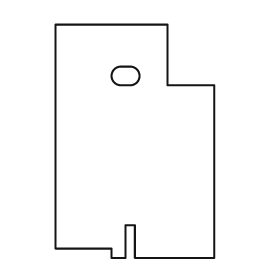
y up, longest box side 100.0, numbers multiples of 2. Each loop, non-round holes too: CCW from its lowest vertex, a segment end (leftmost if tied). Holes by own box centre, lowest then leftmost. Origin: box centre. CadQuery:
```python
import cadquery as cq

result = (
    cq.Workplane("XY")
    .moveTo(-10.0, -50.0)
    .lineTo(-4.0, -50.0)
    .lineTo(-4.0, -36.0)
    .lineTo(0.0, -36.0)
    .lineTo(0.0, -50.0)
    .lineTo(34.0, -50.0)
    .lineTo(34.0, 24.0)
    .lineTo(14.0, 24.0)
    .lineTo(14.0, 50.0)
    .lineTo(-34.0, 50.0)
    .lineTo(-34.0, -46.0)
    .lineTo(-10.0, -46.0)
    .close()
    .moveTo(-6.0, 24.0)
    .lineTo(-2.0, 24.0)
    .threePointArc((2.0, 28.0), (-2.0, 32.0))
    .lineTo(-6.0, 32.0)
    .threePointArc((-10.0, 28.0), (-6.0, 24.0))
    .close()
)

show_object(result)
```